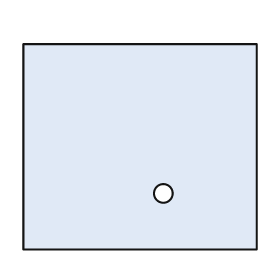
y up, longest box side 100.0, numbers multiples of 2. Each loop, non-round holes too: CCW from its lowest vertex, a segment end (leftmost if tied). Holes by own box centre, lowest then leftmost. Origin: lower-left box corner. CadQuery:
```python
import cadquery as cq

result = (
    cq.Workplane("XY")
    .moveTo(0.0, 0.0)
    .lineTo(100.0, 0.0)
    .lineTo(100.0, 88.0)
    .lineTo(0.0, 88.0)
    .close()
    .moveTo(60.0, 24.0)
    .circle(4.0)
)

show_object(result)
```